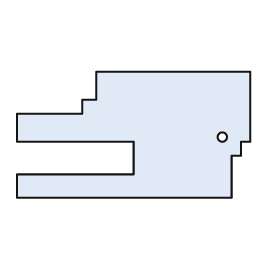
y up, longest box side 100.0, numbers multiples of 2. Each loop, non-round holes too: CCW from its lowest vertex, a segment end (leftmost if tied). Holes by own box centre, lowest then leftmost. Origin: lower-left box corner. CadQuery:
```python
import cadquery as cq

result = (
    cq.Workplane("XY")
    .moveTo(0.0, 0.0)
    .lineTo(92.0, 0.0)
    .lineTo(92.0, 18.0)
    .lineTo(96.0, 18.0)
    .lineTo(96.0, 24.0)
    .lineTo(100.0, 24.0)
    .lineTo(100.0, 54.0)
    .lineTo(34.0, 54.0)
    .lineTo(34.0, 42.0)
    .lineTo(28.0, 42.0)
    .lineTo(28.0, 36.0)
    .lineTo(0.0, 36.0)
    .lineTo(0.0, 24.0)
    .lineTo(50.0, 24.0)
    .lineTo(50.0, 10.0)
    .lineTo(0.0, 10.0)
    .close()
    .moveTo(88.0, 26.0)
    .circle(2.0)
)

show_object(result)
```